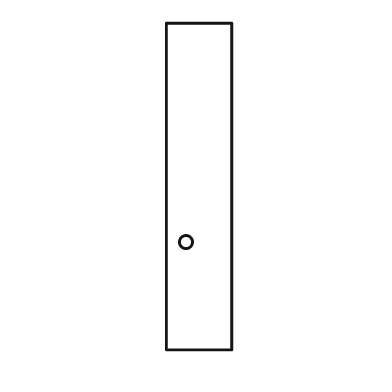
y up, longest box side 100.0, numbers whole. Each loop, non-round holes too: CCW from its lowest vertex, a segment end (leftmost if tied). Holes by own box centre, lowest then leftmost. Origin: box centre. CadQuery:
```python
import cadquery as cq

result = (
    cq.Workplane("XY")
    .moveTo(-10.0, -50.0)
    .lineTo(10.0, -50.0)
    .lineTo(10.0, 50.0)
    .lineTo(-10.0, 50.0)
    .close()
    .moveTo(-4.0, -17.0)
    .circle(2.0)
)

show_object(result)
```